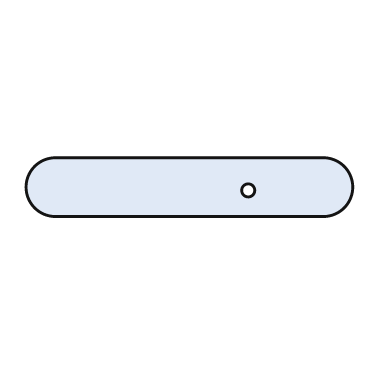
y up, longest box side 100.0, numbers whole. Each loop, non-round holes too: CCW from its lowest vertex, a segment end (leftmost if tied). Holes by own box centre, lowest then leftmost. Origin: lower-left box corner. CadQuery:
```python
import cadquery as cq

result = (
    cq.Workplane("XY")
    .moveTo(9.0, 0.0)
    .lineTo(91.0, 0.0)
    .threePointArc((100.0, 9.0), (91.0, 18.0))
    .lineTo(9.0, 18.0)
    .threePointArc((0.0, 9.0), (9.0, 0.0))
    .close()
    .moveTo(68.0, 8.0)
    .circle(2.0)
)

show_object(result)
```